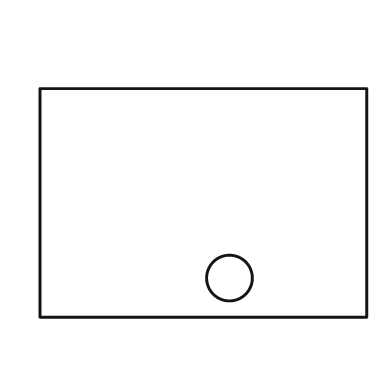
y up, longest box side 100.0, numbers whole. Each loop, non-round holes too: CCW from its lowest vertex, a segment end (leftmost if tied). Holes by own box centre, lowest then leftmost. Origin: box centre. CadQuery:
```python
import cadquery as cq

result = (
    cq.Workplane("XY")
    .moveTo(-50.0, -35.0)
    .lineTo(50.0, -35.0)
    .lineTo(50.0, 35.0)
    .lineTo(-50.0, 35.0)
    .close()
    .moveTo(8.0, -23.0)
    .circle(7.0)
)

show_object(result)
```